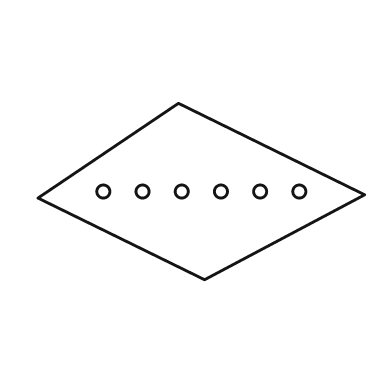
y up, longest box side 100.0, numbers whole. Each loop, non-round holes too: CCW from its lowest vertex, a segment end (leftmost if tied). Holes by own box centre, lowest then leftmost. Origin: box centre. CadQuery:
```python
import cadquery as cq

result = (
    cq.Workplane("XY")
    .moveTo(1.0, -27.0)
    .lineTo(50.0, -1.0)
    .lineTo(-7.0, 27.0)
    .lineTo(-50.0, -2.0)
    .close()
    .moveTo(-30.0, 0.0)
    .circle(2.0)
    .moveTo(-18.0, 0.0)
    .circle(2.0)
    .moveTo(-6.0, 0.0)
    .circle(2.0)
    .moveTo(6.0, 0.0)
    .circle(2.0)
    .moveTo(18.0, 0.0)
    .circle(2.0)
    .moveTo(30.0, 0.0)
    .circle(2.0)
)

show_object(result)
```